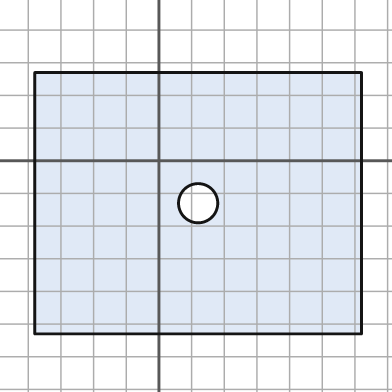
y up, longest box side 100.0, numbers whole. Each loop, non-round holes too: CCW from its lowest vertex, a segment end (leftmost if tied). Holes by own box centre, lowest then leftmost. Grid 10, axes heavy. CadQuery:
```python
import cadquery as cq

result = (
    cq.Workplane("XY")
    .moveTo(-38.0, -53.0)
    .lineTo(62.0, -53.0)
    .lineTo(62.0, 27.0)
    .lineTo(-38.0, 27.0)
    .close()
    .moveTo(12.0, -13.0)
    .circle(6.0)
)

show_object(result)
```